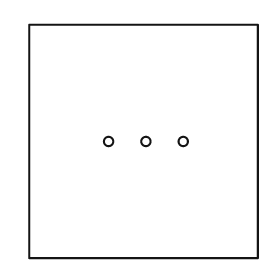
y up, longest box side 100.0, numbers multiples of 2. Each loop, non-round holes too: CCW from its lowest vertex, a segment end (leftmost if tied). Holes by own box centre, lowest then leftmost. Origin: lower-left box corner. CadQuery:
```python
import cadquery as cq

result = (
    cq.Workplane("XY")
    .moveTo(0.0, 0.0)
    .lineTo(98.0, 0.0)
    .lineTo(98.0, 100.0)
    .lineTo(0.0, 100.0)
    .close()
    .moveTo(34.0, 50.0)
    .circle(2.0)
    .moveTo(50.0, 50.0)
    .circle(2.0)
    .moveTo(66.0, 50.0)
    .circle(2.0)
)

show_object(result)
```